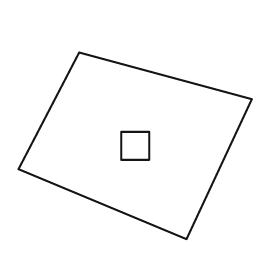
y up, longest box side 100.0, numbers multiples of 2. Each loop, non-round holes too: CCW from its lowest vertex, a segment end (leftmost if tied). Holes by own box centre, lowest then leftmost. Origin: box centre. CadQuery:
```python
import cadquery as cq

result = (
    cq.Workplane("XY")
    .moveTo(22.0, -40.0)
    .lineTo(50.0, 20.0)
    .lineTo(-24.0, 40.0)
    .lineTo(-50.0, -10.0)
    .close()
    .moveTo(-6.0, -6.0)
    .lineTo(6.0, -6.0)
    .lineTo(6.0, 6.0)
    .lineTo(-6.0, 6.0)
    .close()
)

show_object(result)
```